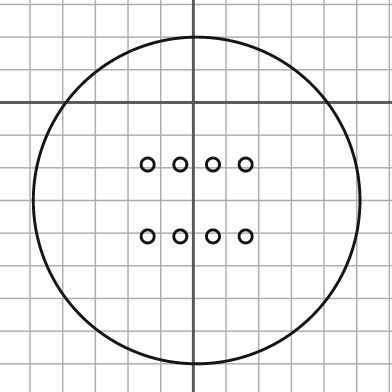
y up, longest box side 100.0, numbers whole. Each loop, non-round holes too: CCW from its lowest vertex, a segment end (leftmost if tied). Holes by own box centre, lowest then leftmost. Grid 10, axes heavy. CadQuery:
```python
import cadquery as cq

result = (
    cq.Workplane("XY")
    .moveTo(1.0, -30.0)
    .circle(50.0)
    .moveTo(-14.0, -41.0)
    .circle(2.0)
    .moveTo(-4.0, -41.0)
    .circle(2.0)
    .moveTo(6.0, -41.0)
    .circle(2.0)
    .moveTo(16.0, -41.0)
    .circle(2.0)
    .moveTo(-14.0, -19.0)
    .circle(2.0)
    .moveTo(-4.0, -19.0)
    .circle(2.0)
    .moveTo(6.0, -19.0)
    .circle(2.0)
    .moveTo(16.0, -19.0)
    .circle(2.0)
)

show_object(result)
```